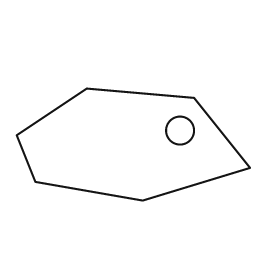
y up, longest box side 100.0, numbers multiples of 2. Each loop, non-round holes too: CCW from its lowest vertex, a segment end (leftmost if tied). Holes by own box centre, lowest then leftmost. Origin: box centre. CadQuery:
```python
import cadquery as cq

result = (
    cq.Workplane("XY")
    .moveTo(4.0, -24.0)
    .lineTo(50.0, -10.0)
    .lineTo(26.0, 20.0)
    .lineTo(-20.0, 24.0)
    .lineTo(-50.0, 4.0)
    .lineTo(-42.0, -16.0)
    .close()
    .moveTo(20.0, 6.0)
    .circle(6.0)
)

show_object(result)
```